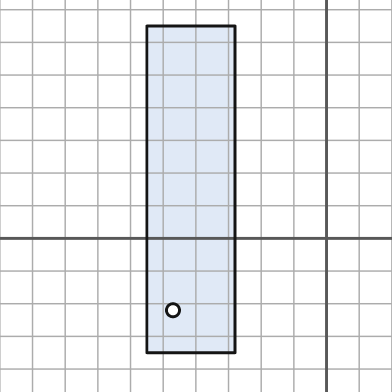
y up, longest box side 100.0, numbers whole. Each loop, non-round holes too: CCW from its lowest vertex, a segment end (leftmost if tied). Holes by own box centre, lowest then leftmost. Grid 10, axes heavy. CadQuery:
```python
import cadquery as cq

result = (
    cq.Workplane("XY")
    .moveTo(-55.0, -35.0)
    .lineTo(-28.0, -35.0)
    .lineTo(-28.0, 65.0)
    .lineTo(-55.0, 65.0)
    .close()
    .moveTo(-47.0, -22.0)
    .circle(2.0)
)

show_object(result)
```